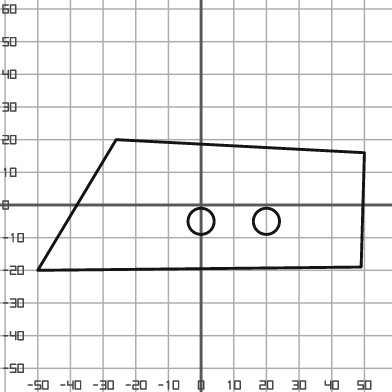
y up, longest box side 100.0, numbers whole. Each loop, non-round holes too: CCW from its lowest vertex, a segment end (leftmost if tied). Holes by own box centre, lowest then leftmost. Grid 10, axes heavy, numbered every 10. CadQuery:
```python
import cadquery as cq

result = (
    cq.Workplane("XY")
    .moveTo(-50.0, -20.0)
    .lineTo(49.0, -19.0)
    .lineTo(50.0, 16.0)
    .lineTo(-26.0, 20.0)
    .close()
    .moveTo(0.0, -5.0)
    .circle(4.0)
    .moveTo(20.0, -5.0)
    .circle(4.0)
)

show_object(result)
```